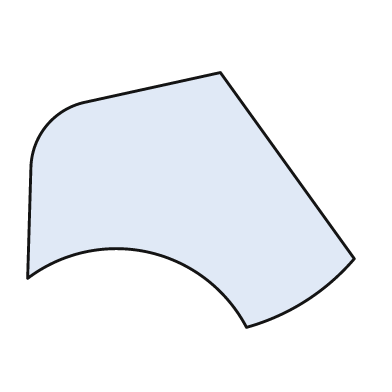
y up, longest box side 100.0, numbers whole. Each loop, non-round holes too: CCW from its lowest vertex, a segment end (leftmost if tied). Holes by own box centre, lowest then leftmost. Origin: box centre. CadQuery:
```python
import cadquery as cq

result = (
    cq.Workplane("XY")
    .moveTo(17.0, -39.0)
    .threePointArc((35.0, -31.0), (50.0, -18.0))
    .lineTo(9.0, 39.0)
    .lineTo(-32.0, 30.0)
    .threePointArc((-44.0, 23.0), (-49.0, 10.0))
    .lineTo(-50.0, -24.0)
    .threePointArc((-13.0, -16.0), (17.0, -39.0))
    .close()
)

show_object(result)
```